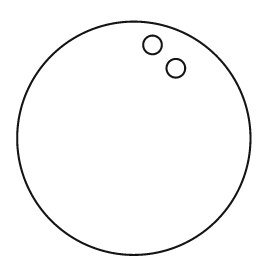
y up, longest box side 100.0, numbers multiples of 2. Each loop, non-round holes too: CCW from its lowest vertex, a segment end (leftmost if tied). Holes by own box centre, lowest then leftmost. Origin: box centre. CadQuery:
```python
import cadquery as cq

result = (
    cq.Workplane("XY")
    .moveTo(0.0, 0.0)
    .circle(50.0)
    .moveTo(18.0, 30.0)
    .circle(4.0)
    .moveTo(8.0, 40.0)
    .circle(4.0)
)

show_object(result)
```